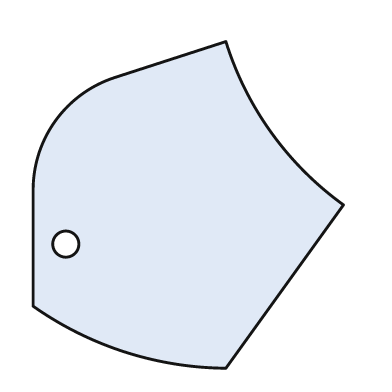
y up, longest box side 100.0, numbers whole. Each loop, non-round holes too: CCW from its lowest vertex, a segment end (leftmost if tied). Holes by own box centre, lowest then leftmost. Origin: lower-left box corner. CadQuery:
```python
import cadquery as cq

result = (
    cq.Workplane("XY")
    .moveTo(59.0, 0.0)
    .lineTo(95.0, 50.0)
    .threePointArc((73.0, 72.0), (59.0, 100.0))
    .lineTo(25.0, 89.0)
    .threePointArc((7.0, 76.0), (0.0, 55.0))
    .lineTo(0.0, 19.0)
    .threePointArc((28.0, 5.0), (59.0, 0.0))
    .close()
    .moveTo(10.0, 38.0)
    .circle(4.0)
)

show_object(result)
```